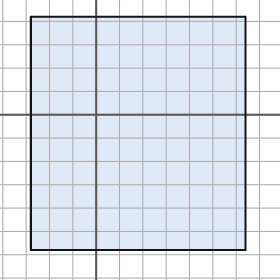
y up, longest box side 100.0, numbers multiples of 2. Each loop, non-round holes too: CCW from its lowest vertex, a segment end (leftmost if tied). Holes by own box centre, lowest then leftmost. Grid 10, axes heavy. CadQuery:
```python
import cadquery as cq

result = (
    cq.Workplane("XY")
    .moveTo(-28.0, -58.0)
    .lineTo(64.0, -58.0)
    .lineTo(64.0, 42.0)
    .lineTo(-28.0, 42.0)
    .close()
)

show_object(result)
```